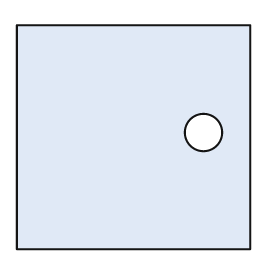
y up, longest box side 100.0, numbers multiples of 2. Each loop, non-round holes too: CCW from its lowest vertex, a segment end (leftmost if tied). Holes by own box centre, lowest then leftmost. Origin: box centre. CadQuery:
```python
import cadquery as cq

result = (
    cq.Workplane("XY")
    .moveTo(-50.0, -48.0)
    .lineTo(50.0, -48.0)
    .lineTo(50.0, 48.0)
    .lineTo(-50.0, 48.0)
    .close()
    .moveTo(30.0, 2.0)
    .circle(8.0)
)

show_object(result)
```